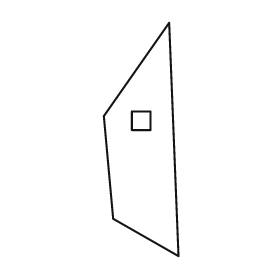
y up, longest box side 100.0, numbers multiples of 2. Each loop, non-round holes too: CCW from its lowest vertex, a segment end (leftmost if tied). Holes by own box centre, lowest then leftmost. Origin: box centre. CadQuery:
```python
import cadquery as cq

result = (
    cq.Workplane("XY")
    .moveTo(16.0, -50.0)
    .lineTo(12.0, 50.0)
    .lineTo(-16.0, 10.0)
    .lineTo(-12.0, -34.0)
    .close()
    .moveTo(-4.0, 4.0)
    .lineTo(4.0, 4.0)
    .lineTo(4.0, 12.0)
    .lineTo(-4.0, 12.0)
    .close()
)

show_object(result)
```